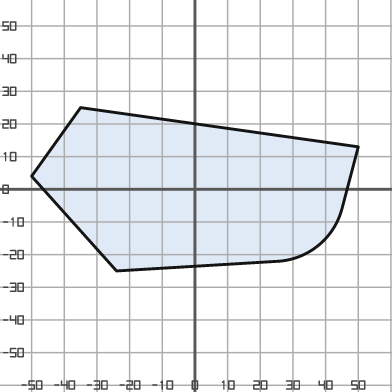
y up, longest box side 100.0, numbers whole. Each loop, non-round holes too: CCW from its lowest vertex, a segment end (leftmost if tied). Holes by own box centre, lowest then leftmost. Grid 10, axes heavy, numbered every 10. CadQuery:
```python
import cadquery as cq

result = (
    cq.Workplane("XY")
    .moveTo(-24.0, -25.0)
    .lineTo(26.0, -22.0)
    .threePointArc((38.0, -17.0), (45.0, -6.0))
    .lineTo(50.0, 13.0)
    .lineTo(-35.0, 25.0)
    .lineTo(-50.0, 4.0)
    .close()
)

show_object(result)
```